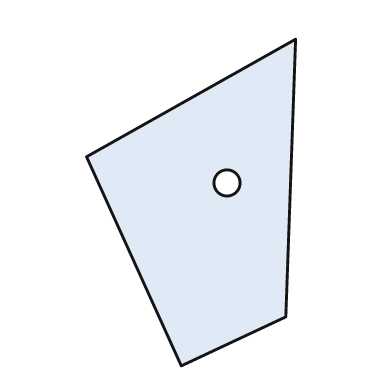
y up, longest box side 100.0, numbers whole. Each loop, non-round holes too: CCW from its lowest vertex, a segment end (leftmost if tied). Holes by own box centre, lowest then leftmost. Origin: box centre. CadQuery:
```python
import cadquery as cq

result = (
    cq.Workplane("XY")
    .moveTo(-3.0, -50.0)
    .lineTo(29.0, -35.0)
    .lineTo(32.0, 50.0)
    .lineTo(-32.0, 14.0)
    .close()
    .moveTo(11.0, 6.0)
    .circle(4.0)
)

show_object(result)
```